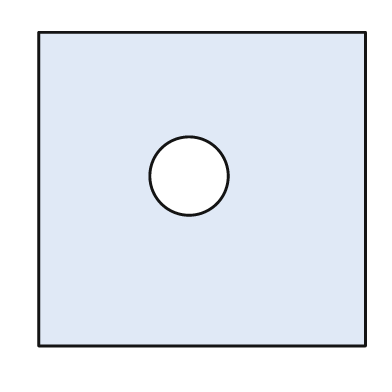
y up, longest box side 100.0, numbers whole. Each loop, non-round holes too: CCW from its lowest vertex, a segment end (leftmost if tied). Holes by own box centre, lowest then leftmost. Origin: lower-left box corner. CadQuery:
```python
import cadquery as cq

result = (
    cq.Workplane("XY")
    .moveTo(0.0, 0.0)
    .lineTo(100.0, 0.0)
    .lineTo(100.0, 96.0)
    .lineTo(0.0, 96.0)
    .close()
    .moveTo(46.0, 52.0)
    .circle(12.0)
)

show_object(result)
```